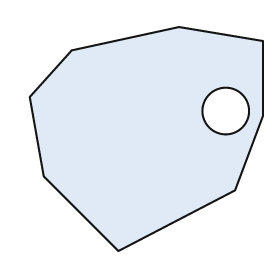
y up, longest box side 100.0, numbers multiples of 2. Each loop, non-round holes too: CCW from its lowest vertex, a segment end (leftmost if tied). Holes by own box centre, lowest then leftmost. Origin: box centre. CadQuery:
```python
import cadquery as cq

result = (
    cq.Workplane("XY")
    .moveTo(-12.0, -48.0)
    .lineTo(38.0, -22.0)
    .lineTo(50.0, 10.0)
    .lineTo(50.0, 42.0)
    .lineTo(14.0, 48.0)
    .lineTo(-32.0, 38.0)
    .lineTo(-50.0, 18.0)
    .lineTo(-44.0, -16.0)
    .close()
    .moveTo(34.0, 12.0)
    .circle(10.0)
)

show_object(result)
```